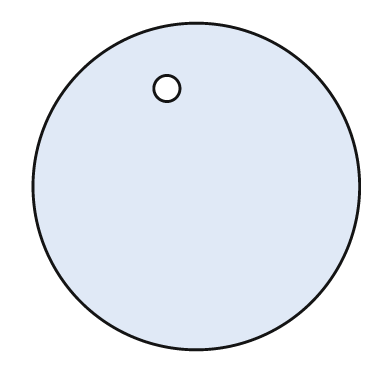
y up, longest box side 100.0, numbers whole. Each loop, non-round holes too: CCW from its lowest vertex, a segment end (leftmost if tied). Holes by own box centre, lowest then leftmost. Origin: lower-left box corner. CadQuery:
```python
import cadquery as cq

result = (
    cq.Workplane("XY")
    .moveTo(50.0, 50.0)
    .circle(50.0)
    .moveTo(41.0, 80.0)
    .circle(4.0)
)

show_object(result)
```